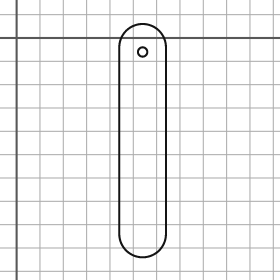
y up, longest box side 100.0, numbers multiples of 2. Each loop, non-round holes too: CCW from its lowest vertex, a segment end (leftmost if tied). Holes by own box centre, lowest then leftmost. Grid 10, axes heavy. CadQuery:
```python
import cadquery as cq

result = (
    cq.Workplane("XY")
    .moveTo(44.0, -84.0)
    .threePointArc((54.0, -94.0), (64.0, -84.0))
    .lineTo(64.0, -4.0)
    .threePointArc((54.0, 6.0), (44.0, -4.0))
    .close()
    .moveTo(54.0, -6.0)
    .circle(2.0)
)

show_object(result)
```